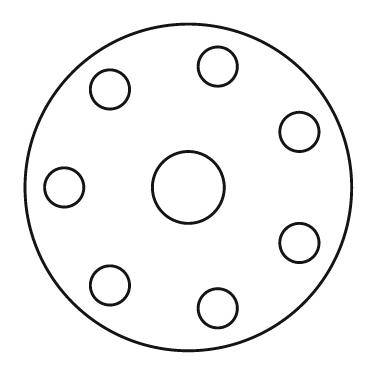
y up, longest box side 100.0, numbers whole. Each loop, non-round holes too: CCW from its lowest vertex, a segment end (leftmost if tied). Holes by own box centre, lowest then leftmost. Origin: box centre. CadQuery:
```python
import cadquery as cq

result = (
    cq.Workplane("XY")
    .moveTo(0.0, 0.0)
    .circle(50.0)
    .moveTo(9.0, -37.0)
    .circle(6.0)
    .moveTo(-24.0, -30.0)
    .circle(6.0)
    .moveTo(34.0, -17.0)
    .circle(6.0)
    .moveTo(-38.0, 0.0)
    .circle(6.0)
    .moveTo(0.0, 0.0)
    .circle(11.0)
    .moveTo(34.0, 17.0)
    .circle(6.0)
    .moveTo(-24.0, 30.0)
    .circle(6.0)
    .moveTo(9.0, 37.0)
    .circle(6.0)
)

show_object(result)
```